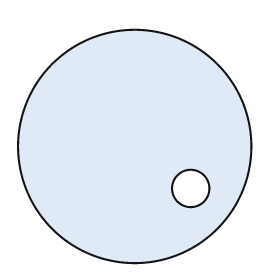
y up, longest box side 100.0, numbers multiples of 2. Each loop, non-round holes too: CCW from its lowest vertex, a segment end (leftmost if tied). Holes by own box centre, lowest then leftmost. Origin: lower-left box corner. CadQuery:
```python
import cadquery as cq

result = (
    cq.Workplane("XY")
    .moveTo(50.0, 50.0)
    .circle(50.0)
    .moveTo(74.0, 32.0)
    .circle(8.0)
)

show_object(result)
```